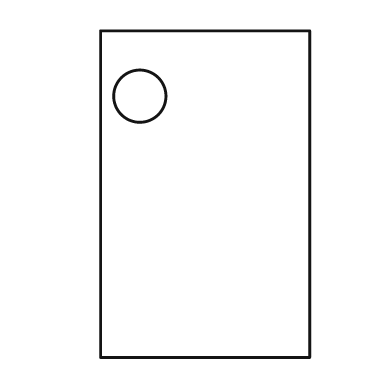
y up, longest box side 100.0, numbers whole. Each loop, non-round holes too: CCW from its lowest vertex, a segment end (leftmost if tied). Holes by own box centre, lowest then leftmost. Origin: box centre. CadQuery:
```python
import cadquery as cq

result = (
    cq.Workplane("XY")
    .moveTo(-32.0, -50.0)
    .lineTo(32.0, -50.0)
    .lineTo(32.0, 50.0)
    .lineTo(-32.0, 50.0)
    .close()
    .moveTo(-20.0, 30.0)
    .circle(8.0)
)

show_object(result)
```